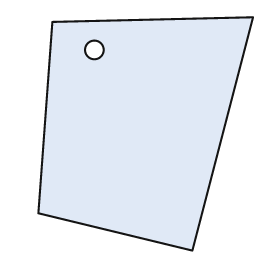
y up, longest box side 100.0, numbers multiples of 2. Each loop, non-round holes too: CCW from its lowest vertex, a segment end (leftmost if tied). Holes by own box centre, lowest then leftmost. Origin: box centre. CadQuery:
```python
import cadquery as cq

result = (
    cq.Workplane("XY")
    .moveTo(20.0, -50.0)
    .lineTo(46.0, 50.0)
    .lineTo(-40.0, 48.0)
    .lineTo(-46.0, -34.0)
    .close()
    .moveTo(-22.0, 36.0)
    .circle(4.0)
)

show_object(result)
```